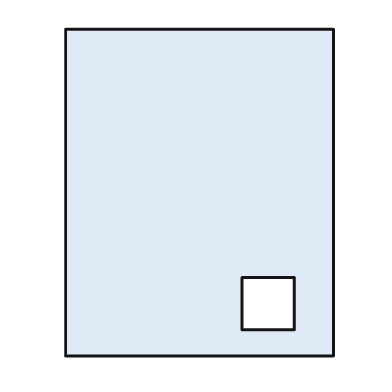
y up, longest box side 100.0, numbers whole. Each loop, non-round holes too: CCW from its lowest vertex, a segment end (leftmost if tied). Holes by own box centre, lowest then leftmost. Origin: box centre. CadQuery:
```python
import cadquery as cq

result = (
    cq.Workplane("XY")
    .moveTo(-41.0, -50.0)
    .lineTo(41.0, -50.0)
    .lineTo(41.0, 50.0)
    .lineTo(-41.0, 50.0)
    .close()
    .moveTo(13.0, -42.0)
    .lineTo(29.0, -42.0)
    .lineTo(29.0, -26.0)
    .lineTo(13.0, -26.0)
    .close()
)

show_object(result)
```